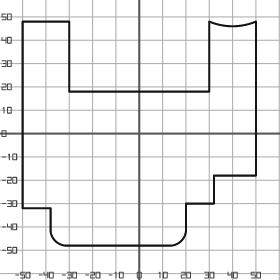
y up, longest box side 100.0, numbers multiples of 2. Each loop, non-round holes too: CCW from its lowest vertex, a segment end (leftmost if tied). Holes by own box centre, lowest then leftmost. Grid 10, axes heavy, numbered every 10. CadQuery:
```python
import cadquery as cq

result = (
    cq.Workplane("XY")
    .moveTo(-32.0, -48.0)
    .lineTo(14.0, -48.0)
    .threePointArc((18.0, -46.0), (20.0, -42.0))
    .lineTo(20.0, -30.0)
    .lineTo(32.0, -30.0)
    .lineTo(32.0, -18.0)
    .lineTo(50.0, -18.0)
    .lineTo(50.0, 48.0)
    .threePointArc((40.0, 46.0), (30.0, 48.0))
    .lineTo(30.0, 18.0)
    .lineTo(-30.0, 18.0)
    .lineTo(-30.0, 48.0)
    .lineTo(-50.0, 48.0)
    .lineTo(-50.0, -32.0)
    .lineTo(-38.0, -32.0)
    .lineTo(-38.0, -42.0)
    .threePointArc((-36.0, -46.0), (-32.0, -48.0))
    .close()
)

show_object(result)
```